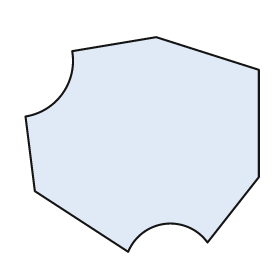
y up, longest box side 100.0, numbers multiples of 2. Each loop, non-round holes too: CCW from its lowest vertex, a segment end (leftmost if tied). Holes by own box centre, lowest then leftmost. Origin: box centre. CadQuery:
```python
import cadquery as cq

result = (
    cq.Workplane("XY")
    .moveTo(-6.0, -46.0)
    .threePointArc((10.0, -34.0), (28.0, -42.0))
    .lineTo(50.0, -14.0)
    .lineTo(50.0, 32.0)
    .lineTo(6.0, 46.0)
    .lineTo(-30.0, 40.0)
    .threePointArc((-34.0, 22.0), (-50.0, 12.0))
    .lineTo(-46.0, -20.0)
    .close()
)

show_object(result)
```